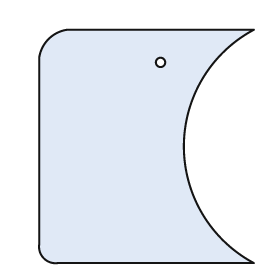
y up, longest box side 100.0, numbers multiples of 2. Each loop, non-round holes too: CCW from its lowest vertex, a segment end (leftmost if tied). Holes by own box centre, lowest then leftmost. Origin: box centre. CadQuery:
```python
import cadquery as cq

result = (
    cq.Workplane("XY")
    .moveTo(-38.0, -50.0)
    .lineTo(46.0, -50.0)
    .threePointArc((16.0, 0.0), (46.0, 50.0))
    .lineTo(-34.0, 50.0)
    .threePointArc((-42.0, 46.0), (-46.0, 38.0))
    .lineTo(-46.0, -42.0)
    .threePointArc((-44.0, -48.0), (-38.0, -50.0))
    .close()
    .moveTo(6.0, 36.0)
    .circle(2.0)
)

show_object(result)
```